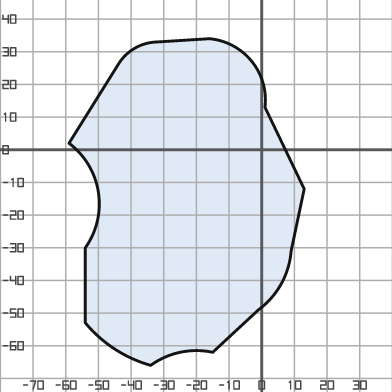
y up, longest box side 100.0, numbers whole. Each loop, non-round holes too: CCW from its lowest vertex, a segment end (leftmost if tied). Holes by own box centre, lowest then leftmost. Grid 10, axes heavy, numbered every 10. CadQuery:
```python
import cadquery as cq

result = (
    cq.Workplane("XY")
    .moveTo(-34.0, -66.0)
    .threePointArc((-25.0, -62.0), (-15.0, -62.0))
    .lineTo(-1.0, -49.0)
    .threePointArc((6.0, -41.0), (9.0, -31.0))
    .lineTo(13.0, -12.0)
    .lineTo(1.0, 13.0)
    .threePointArc((-3.0, 27.0), (-16.0, 34.0))
    .lineTo(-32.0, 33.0)
    .threePointArc((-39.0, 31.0), (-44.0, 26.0))
    .lineTo(-59.0, 2.0)
    .threePointArc((-50.0, -13.0), (-54.0, -30.0))
    .lineTo(-54.0, -53.0)
    .threePointArc((-45.0, -61.0), (-34.0, -66.0))
    .close()
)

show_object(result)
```